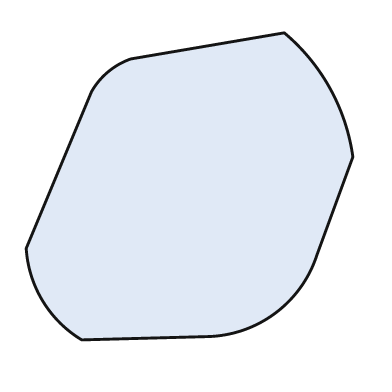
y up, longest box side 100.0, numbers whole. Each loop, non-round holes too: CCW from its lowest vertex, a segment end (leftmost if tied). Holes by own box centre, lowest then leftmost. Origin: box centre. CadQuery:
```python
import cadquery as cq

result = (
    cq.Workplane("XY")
    .moveTo(-33.0, -47.0)
    .lineTo(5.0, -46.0)
    .threePointArc((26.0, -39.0), (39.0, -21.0))
    .lineTo(50.0, 9.0)
    .threePointArc((43.0, 30.0), (29.0, 47.0))
    .lineTo(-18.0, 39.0)
    .threePointArc((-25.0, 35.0), (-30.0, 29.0))
    .lineTo(-50.0, -19.0)
    .threePointArc((-45.0, -35.0), (-33.0, -47.0))
    .close()
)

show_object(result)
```